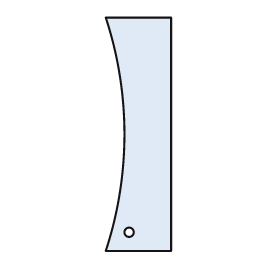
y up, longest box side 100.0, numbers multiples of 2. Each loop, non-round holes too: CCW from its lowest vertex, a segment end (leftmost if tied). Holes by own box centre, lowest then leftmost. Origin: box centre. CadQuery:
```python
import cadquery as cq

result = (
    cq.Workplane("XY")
    .moveTo(-14.0, -50.0)
    .lineTo(14.0, -50.0)
    .lineTo(14.0, 50.0)
    .lineTo(-14.0, 50.0)
    .threePointArc((-6.0, 0.0), (-14.0, -50.0))
    .close()
    .moveTo(-4.0, -42.0)
    .circle(2.0)
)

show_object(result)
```